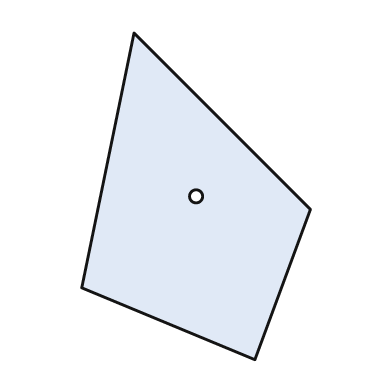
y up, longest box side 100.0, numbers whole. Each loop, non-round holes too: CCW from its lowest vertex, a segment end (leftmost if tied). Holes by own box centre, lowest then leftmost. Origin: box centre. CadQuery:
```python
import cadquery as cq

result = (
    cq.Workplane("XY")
    .moveTo(18.0, -50.0)
    .lineTo(35.0, -4.0)
    .lineTo(-19.0, 50.0)
    .lineTo(-35.0, -28.0)
    .close()
    .moveTo(0.0, 0.0)
    .circle(2.0)
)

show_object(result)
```